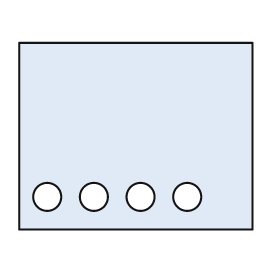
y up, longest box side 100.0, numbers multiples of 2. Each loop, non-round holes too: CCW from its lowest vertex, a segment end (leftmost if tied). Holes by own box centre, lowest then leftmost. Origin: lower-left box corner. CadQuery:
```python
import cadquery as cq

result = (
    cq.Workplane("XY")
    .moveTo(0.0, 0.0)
    .lineTo(100.0, 0.0)
    .lineTo(100.0, 80.0)
    .lineTo(0.0, 80.0)
    .close()
    .moveTo(12.0, 14.0)
    .circle(6.0)
    .moveTo(32.0, 14.0)
    .circle(6.0)
    .moveTo(52.0, 14.0)
    .circle(6.0)
    .moveTo(72.0, 14.0)
    .circle(6.0)
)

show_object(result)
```